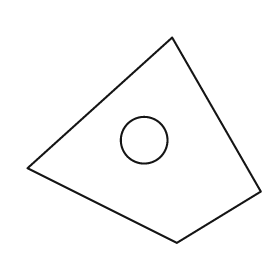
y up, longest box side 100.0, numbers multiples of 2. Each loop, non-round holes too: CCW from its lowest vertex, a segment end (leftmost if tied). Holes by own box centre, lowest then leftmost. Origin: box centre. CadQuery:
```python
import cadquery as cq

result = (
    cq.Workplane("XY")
    .moveTo(14.0, -44.0)
    .lineTo(50.0, -22.0)
    .lineTo(12.0, 44.0)
    .lineTo(-50.0, -12.0)
    .close()
    .moveTo(0.0, 0.0)
    .circle(10.0)
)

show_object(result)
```